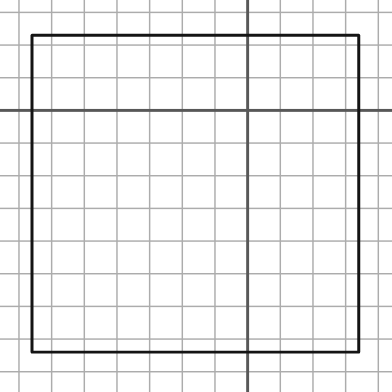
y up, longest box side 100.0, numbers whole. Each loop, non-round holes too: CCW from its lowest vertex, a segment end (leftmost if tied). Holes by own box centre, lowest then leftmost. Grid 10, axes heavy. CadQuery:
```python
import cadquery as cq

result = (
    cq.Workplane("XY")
    .moveTo(-66.0, -74.0)
    .lineTo(34.0, -74.0)
    .lineTo(34.0, 23.0)
    .lineTo(-66.0, 23.0)
    .close()
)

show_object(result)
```